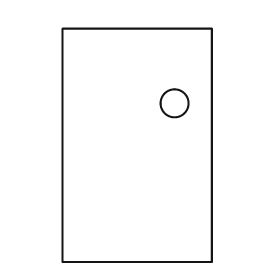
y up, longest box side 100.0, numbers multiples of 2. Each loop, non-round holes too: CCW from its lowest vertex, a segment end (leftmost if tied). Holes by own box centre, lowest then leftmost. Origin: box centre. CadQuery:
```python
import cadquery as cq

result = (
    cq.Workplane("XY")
    .moveTo(-32.0, -50.0)
    .lineTo(32.0, -50.0)
    .lineTo(32.0, 50.0)
    .lineTo(-32.0, 50.0)
    .close()
    .moveTo(16.0, 18.0)
    .circle(6.0)
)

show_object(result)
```